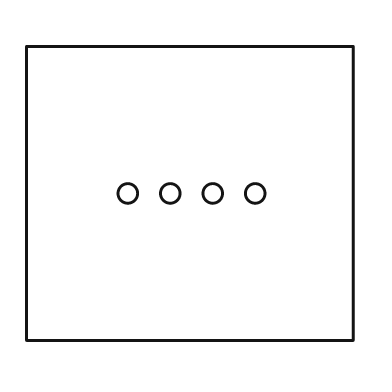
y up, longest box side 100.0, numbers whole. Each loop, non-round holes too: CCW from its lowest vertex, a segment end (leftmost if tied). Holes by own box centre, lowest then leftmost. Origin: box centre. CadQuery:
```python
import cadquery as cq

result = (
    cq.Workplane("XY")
    .moveTo(-50.0, -45.0)
    .lineTo(50.0, -45.0)
    .lineTo(50.0, 45.0)
    .lineTo(-50.0, 45.0)
    .close()
    .moveTo(-19.0, 0.0)
    .circle(3.0)
    .moveTo(-6.0, 0.0)
    .circle(3.0)
    .moveTo(7.0, 0.0)
    .circle(3.0)
    .moveTo(20.0, 0.0)
    .circle(3.0)
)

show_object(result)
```